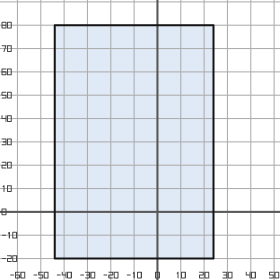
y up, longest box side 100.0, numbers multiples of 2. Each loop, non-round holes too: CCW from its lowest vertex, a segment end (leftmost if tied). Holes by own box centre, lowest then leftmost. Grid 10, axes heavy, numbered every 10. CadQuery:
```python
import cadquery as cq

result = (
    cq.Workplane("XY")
    .moveTo(-44.0, -20.0)
    .lineTo(24.0, -20.0)
    .lineTo(24.0, 80.0)
    .lineTo(-44.0, 80.0)
    .close()
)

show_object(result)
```